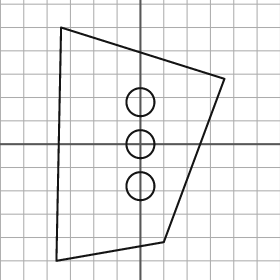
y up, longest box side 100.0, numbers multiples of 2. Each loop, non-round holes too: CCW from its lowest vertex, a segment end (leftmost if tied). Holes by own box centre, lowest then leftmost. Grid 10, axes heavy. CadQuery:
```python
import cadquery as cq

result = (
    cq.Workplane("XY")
    .moveTo(-36.0, -50.0)
    .lineTo(10.0, -42.0)
    .lineTo(36.0, 28.0)
    .lineTo(-34.0, 50.0)
    .close()
    .moveTo(0.0, -18.0)
    .circle(6.0)
    .moveTo(0.0, 0.0)
    .circle(6.0)
    .moveTo(0.0, 18.0)
    .circle(6.0)
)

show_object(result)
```